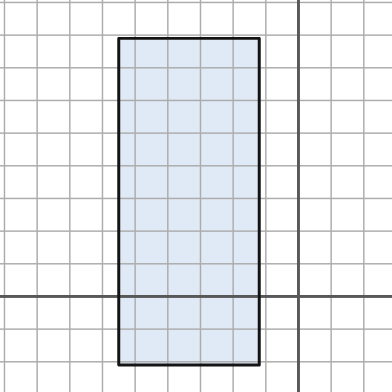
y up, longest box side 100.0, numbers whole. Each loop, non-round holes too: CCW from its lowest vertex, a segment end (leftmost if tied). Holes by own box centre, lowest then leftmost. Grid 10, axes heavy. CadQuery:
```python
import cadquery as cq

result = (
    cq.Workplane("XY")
    .moveTo(-55.0, -21.0)
    .lineTo(-12.0, -21.0)
    .lineTo(-12.0, 79.0)
    .lineTo(-55.0, 79.0)
    .close()
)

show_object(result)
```